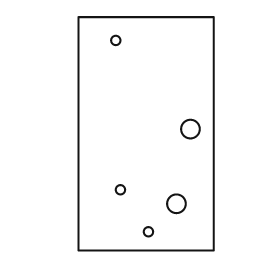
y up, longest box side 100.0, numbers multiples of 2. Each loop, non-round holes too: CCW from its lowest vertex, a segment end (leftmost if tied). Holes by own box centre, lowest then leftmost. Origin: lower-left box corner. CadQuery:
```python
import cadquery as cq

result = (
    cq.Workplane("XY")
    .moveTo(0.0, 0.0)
    .lineTo(58.0, 0.0)
    .lineTo(58.0, 100.0)
    .lineTo(0.0, 100.0)
    .close()
    .moveTo(30.0, 8.0)
    .circle(2.0)
    .moveTo(42.0, 20.0)
    .circle(4.0)
    .moveTo(18.0, 26.0)
    .circle(2.0)
    .moveTo(48.0, 52.0)
    .circle(4.0)
    .moveTo(16.0, 90.0)
    .circle(2.0)
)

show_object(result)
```